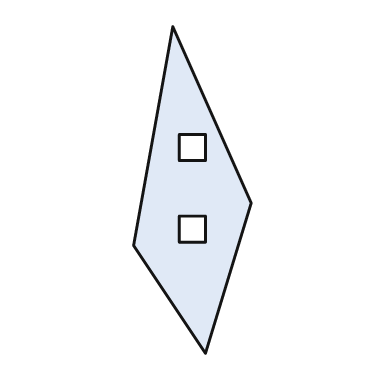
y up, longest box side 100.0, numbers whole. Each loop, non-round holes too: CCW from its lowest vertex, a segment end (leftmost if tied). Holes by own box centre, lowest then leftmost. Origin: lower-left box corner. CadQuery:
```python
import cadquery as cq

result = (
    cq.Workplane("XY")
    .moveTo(22.0, 0.0)
    .lineTo(36.0, 46.0)
    .lineTo(12.0, 100.0)
    .lineTo(0.0, 33.0)
    .close()
    .moveTo(14.0, 34.0)
    .lineTo(22.0, 34.0)
    .lineTo(22.0, 42.0)
    .lineTo(14.0, 42.0)
    .close()
    .moveTo(14.0, 59.0)
    .lineTo(22.0, 59.0)
    .lineTo(22.0, 67.0)
    .lineTo(14.0, 67.0)
    .close()
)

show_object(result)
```